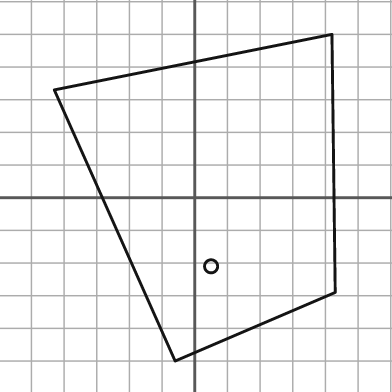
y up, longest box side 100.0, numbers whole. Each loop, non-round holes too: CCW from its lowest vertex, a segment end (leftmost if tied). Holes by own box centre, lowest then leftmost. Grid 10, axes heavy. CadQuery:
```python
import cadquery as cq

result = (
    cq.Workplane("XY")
    .moveTo(-6.0, -50.0)
    .lineTo(43.0, -29.0)
    .lineTo(42.0, 50.0)
    .lineTo(-43.0, 33.0)
    .close()
    .moveTo(5.0, -21.0)
    .circle(2.0)
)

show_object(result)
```